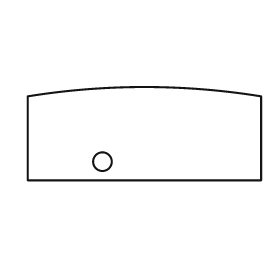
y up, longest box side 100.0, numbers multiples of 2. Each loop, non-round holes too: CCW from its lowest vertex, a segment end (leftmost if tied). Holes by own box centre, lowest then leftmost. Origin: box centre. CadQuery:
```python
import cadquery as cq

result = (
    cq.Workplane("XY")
    .moveTo(-50.0, -20.0)
    .lineTo(50.0, -20.0)
    .lineTo(50.0, 16.0)
    .threePointArc((0.0, 20.0), (-50.0, 16.0))
    .close()
    .moveTo(-18.0, -12.0)
    .circle(4.0)
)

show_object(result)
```